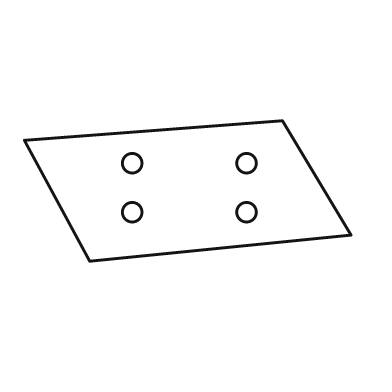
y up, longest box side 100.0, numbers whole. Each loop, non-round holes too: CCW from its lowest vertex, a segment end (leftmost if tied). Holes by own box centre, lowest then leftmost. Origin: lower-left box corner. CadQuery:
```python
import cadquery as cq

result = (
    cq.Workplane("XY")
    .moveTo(20.0, 0.0)
    .lineTo(100.0, 8.0)
    .lineTo(79.0, 43.0)
    .lineTo(0.0, 37.0)
    .close()
    .moveTo(33.0, 15.0)
    .circle(3.0)
    .moveTo(68.0, 15.0)
    .circle(3.0)
    .moveTo(33.0, 30.0)
    .circle(3.0)
    .moveTo(68.0, 30.0)
    .circle(3.0)
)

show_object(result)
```